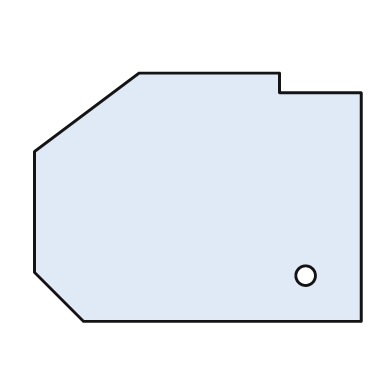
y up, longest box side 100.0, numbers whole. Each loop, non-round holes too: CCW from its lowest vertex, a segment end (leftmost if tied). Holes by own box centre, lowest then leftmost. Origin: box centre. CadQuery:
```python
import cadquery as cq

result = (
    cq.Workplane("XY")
    .moveTo(-35.0, -38.0)
    .lineTo(50.0, -38.0)
    .lineTo(50.0, 32.0)
    .lineTo(25.0, 32.0)
    .lineTo(25.0, 38.0)
    .lineTo(-18.0, 38.0)
    .lineTo(-50.0, 14.0)
    .lineTo(-50.0, -23.0)
    .close()
    .moveTo(33.0, -24.0)
    .circle(3.0)
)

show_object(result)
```